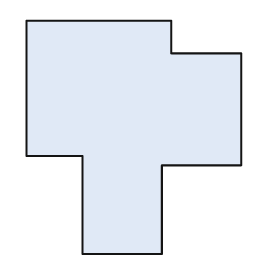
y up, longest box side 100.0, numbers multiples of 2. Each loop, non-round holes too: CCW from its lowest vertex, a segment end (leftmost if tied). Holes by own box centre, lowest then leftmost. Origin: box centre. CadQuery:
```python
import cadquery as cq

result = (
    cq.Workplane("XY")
    .moveTo(-22.0, -50.0)
    .lineTo(12.0, -50.0)
    .lineTo(12.0, -12.0)
    .lineTo(46.0, -12.0)
    .lineTo(46.0, 36.0)
    .lineTo(16.0, 36.0)
    .lineTo(16.0, 50.0)
    .lineTo(-46.0, 50.0)
    .lineTo(-46.0, -8.0)
    .lineTo(-22.0, -8.0)
    .close()
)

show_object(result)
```